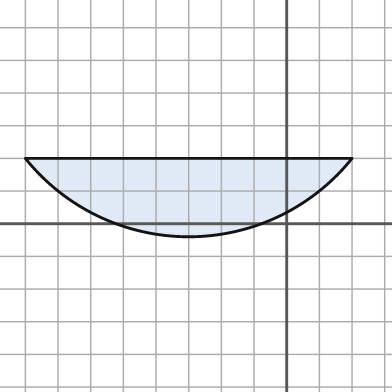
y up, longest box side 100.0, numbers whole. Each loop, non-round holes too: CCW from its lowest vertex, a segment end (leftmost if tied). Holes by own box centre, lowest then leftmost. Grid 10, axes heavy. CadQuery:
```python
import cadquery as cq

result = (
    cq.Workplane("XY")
    .moveTo(-80.0, 20.0)
    .threePointArc((-30.0, -4.0), (20.0, 20.0))
    .close()
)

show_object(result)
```